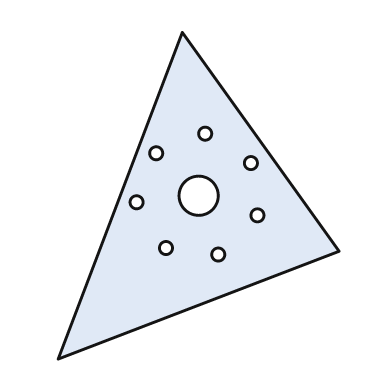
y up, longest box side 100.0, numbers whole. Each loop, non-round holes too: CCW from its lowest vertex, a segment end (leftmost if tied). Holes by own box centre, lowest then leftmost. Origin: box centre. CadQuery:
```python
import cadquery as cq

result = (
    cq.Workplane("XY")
    .moveTo(-43.0, -50.0)
    .lineTo(43.0, -17.0)
    .lineTo(-5.0, 50.0)
    .close()
    .moveTo(6.0, -18.0)
    .circle(2.0)
    .moveTo(-10.0, -16.0)
    .circle(2.0)
    .moveTo(18.0, -6.0)
    .circle(2.0)
    .moveTo(-19.0, -2.0)
    .circle(2.0)
    .moveTo(0.0, 0.0)
    .circle(6.0)
    .moveTo(16.0, 10.0)
    .circle(2.0)
    .moveTo(-13.0, 13.0)
    .circle(2.0)
    .moveTo(2.0, 19.0)
    .circle(2.0)
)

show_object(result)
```